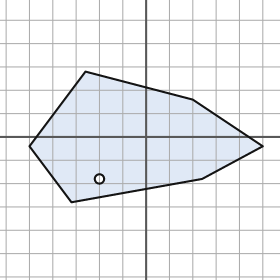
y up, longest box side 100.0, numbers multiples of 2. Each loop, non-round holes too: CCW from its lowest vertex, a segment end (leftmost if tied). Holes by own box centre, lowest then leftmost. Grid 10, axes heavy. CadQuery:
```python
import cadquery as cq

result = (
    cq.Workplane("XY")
    .moveTo(-32.0, -28.0)
    .lineTo(24.0, -18.0)
    .lineTo(50.0, -4.0)
    .lineTo(20.0, 16.0)
    .lineTo(-26.0, 28.0)
    .lineTo(-50.0, -4.0)
    .close()
    .moveTo(-20.0, -18.0)
    .circle(2.0)
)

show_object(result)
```